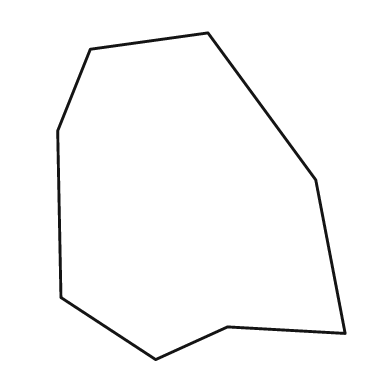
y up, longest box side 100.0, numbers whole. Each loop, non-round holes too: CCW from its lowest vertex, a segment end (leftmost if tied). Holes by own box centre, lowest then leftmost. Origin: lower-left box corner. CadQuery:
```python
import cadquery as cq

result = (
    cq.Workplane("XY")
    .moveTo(30.0, 0.0)
    .lineTo(52.0, 10.0)
    .lineTo(88.0, 8.0)
    .lineTo(79.0, 55.0)
    .lineTo(46.0, 100.0)
    .lineTo(10.0, 95.0)
    .lineTo(0.0, 70.0)
    .lineTo(1.0, 19.0)
    .close()
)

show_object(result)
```